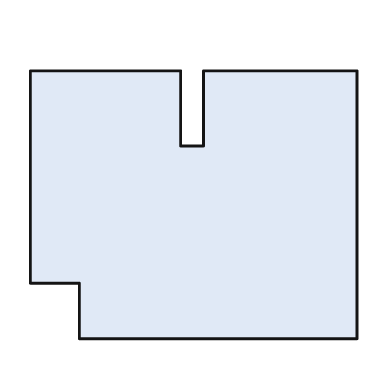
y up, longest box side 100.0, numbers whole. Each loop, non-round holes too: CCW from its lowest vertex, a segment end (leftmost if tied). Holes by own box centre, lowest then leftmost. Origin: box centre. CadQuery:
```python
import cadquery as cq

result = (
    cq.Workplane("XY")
    .moveTo(-35.0, -41.0)
    .lineTo(50.0, -41.0)
    .lineTo(50.0, 41.0)
    .lineTo(3.0, 41.0)
    .lineTo(3.0, 18.0)
    .lineTo(-4.0, 18.0)
    .lineTo(-4.0, 41.0)
    .lineTo(-50.0, 41.0)
    .lineTo(-50.0, -24.0)
    .lineTo(-35.0, -24.0)
    .close()
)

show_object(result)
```